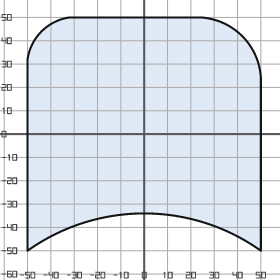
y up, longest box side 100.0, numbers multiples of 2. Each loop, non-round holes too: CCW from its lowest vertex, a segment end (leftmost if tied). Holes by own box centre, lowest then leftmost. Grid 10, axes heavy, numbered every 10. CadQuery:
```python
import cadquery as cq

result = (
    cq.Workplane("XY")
    .moveTo(-50.0, -50.0)
    .threePointArc((0.0, -34.0), (50.0, -50.0))
    .lineTo(50.0, 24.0)
    .threePointArc((42.0, 42.0), (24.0, 50.0))
    .lineTo(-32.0, 50.0)
    .threePointArc((-44.0, 44.0), (-50.0, 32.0))
    .close()
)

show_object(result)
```